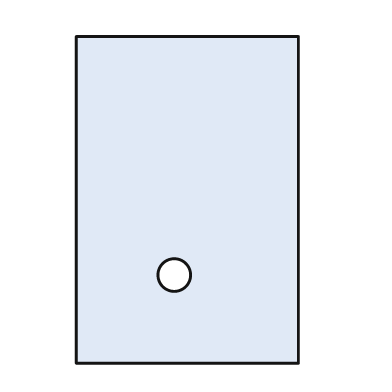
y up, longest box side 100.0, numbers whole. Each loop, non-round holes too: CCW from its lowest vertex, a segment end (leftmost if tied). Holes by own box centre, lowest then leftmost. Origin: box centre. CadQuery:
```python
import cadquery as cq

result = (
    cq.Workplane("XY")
    .moveTo(-34.0, -50.0)
    .lineTo(34.0, -50.0)
    .lineTo(34.0, 50.0)
    .lineTo(-34.0, 50.0)
    .close()
    .moveTo(-4.0, -23.0)
    .circle(5.0)
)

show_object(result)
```